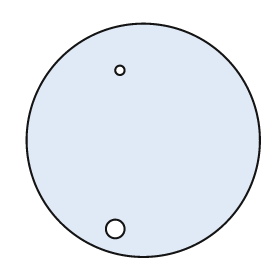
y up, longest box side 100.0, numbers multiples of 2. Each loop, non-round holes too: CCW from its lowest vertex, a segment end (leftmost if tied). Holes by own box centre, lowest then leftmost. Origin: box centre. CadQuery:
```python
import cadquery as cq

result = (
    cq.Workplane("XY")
    .moveTo(0.0, 0.0)
    .circle(50.0)
    .moveTo(-12.0, -38.0)
    .circle(4.0)
    .moveTo(-10.0, 30.0)
    .circle(2.0)
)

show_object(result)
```